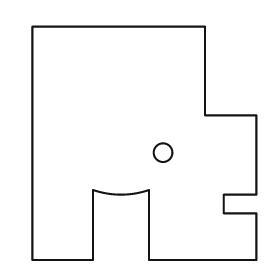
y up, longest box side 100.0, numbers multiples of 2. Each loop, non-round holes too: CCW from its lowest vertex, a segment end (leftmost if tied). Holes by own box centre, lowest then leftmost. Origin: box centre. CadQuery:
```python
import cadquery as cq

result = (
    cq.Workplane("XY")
    .moveTo(-48.0, -50.0)
    .lineTo(-22.0, -50.0)
    .lineTo(-22.0, -20.0)
    .threePointArc((-10.0, -22.0), (2.0, -20.0))
    .lineTo(2.0, -50.0)
    .lineTo(48.0, -50.0)
    .lineTo(48.0, -30.0)
    .lineTo(34.0, -30.0)
    .lineTo(34.0, -22.0)
    .lineTo(48.0, -22.0)
    .lineTo(48.0, 12.0)
    .lineTo(26.0, 12.0)
    .lineTo(26.0, 50.0)
    .lineTo(-48.0, 50.0)
    .close()
    .moveTo(8.0, -4.0)
    .circle(4.0)
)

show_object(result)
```